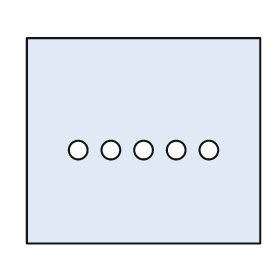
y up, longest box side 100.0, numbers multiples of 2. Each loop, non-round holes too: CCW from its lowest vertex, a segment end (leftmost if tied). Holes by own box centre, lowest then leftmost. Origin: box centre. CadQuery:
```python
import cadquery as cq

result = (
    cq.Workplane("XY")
    .moveTo(-50.0, -44.0)
    .lineTo(50.0, -44.0)
    .lineTo(50.0, 44.0)
    .lineTo(-50.0, 44.0)
    .close()
    .moveTo(-28.0, -4.0)
    .circle(4.0)
    .moveTo(-14.0, -4.0)
    .circle(4.0)
    .moveTo(0.0, -4.0)
    .circle(4.0)
    .moveTo(14.0, -4.0)
    .circle(4.0)
    .moveTo(28.0, -4.0)
    .circle(4.0)
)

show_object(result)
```